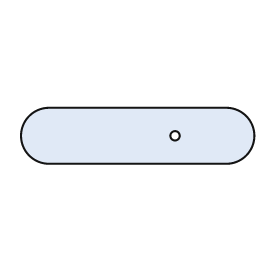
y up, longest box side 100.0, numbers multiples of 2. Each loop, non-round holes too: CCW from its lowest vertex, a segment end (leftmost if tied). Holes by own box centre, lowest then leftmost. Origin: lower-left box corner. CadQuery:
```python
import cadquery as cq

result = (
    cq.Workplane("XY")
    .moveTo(12.0, 0.0)
    .lineTo(88.0, 0.0)
    .threePointArc((100.0, 12.0), (88.0, 24.0))
    .lineTo(12.0, 24.0)
    .threePointArc((0.0, 12.0), (12.0, 0.0))
    .close()
    .moveTo(66.0, 12.0)
    .circle(2.0)
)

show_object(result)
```